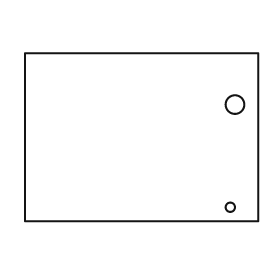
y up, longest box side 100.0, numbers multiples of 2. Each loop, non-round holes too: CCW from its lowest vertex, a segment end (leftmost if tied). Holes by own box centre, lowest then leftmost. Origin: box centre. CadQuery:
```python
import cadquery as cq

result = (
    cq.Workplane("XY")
    .moveTo(-50.0, -36.0)
    .lineTo(50.0, -36.0)
    .lineTo(50.0, 36.0)
    .lineTo(-50.0, 36.0)
    .close()
    .moveTo(38.0, -30.0)
    .circle(2.0)
    .moveTo(40.0, 14.0)
    .circle(4.0)
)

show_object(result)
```